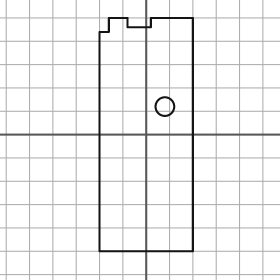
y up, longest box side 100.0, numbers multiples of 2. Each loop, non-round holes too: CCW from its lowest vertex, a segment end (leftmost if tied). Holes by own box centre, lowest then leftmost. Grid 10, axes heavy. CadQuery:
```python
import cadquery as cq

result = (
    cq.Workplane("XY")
    .moveTo(-20.0, -50.0)
    .lineTo(20.0, -50.0)
    .lineTo(20.0, 50.0)
    .lineTo(2.0, 50.0)
    .lineTo(2.0, 46.0)
    .lineTo(-8.0, 46.0)
    .lineTo(-8.0, 50.0)
    .lineTo(-16.0, 50.0)
    .lineTo(-16.0, 44.0)
    .lineTo(-20.0, 44.0)
    .close()
    .moveTo(8.0, 12.0)
    .circle(4.0)
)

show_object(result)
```